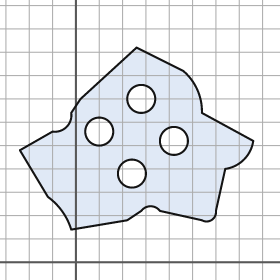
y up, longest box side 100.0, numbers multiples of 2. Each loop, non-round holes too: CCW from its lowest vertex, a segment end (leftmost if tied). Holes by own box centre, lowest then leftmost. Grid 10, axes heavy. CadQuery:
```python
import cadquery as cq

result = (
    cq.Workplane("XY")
    .moveTo(-2.0, 14.0)
    .lineTo(22.0, 18.0)
    .lineTo(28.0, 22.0)
    .threePointArc((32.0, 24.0), (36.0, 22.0))
    .lineTo(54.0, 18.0)
    .threePointArc((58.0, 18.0), (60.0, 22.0))
    .lineTo(64.0, 40.0)
    .threePointArc((72.0, 44.0), (76.0, 52.0))
    .lineTo(54.0, 64.0)
    .threePointArc((52.0, 74.0), (46.0, 82.0))
    .lineTo(26.0, 92.0)
    .lineTo(2.0, 70.0)
    .lineTo(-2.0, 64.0)
    .threePointArc((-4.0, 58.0), (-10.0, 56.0))
    .lineTo(-24.0, 48.0)
    .lineTo(-12.0, 28.0)
    .threePointArc((-6.0, 22.0), (-2.0, 14.0))
    .close()
    .moveTo(24.0, 38.0)
    .circle(6.0)
    .moveTo(42.0, 52.0)
    .circle(6.0)
    .moveTo(10.0, 56.0)
    .circle(6.0)
    .moveTo(28.0, 70.0)
    .circle(6.0)
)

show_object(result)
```